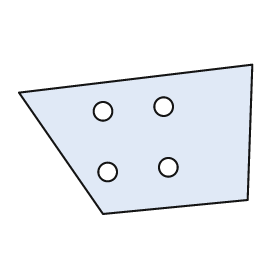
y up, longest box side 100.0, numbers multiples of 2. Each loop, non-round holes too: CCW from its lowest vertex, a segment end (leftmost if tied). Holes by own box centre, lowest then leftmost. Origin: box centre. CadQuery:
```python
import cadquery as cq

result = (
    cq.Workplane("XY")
    .moveTo(-14.0, -32.0)
    .lineTo(48.0, -26.0)
    .lineTo(50.0, 32.0)
    .lineTo(-50.0, 20.0)
    .close()
    .moveTo(-12.0, -14.0)
    .circle(4.0)
    .moveTo(14.0, -12.0)
    .circle(4.0)
    .moveTo(-14.0, 12.0)
    .circle(4.0)
    .moveTo(12.0, 14.0)
    .circle(4.0)
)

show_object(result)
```